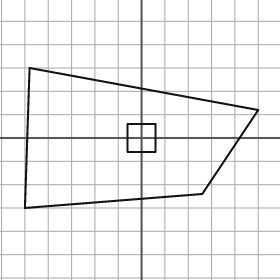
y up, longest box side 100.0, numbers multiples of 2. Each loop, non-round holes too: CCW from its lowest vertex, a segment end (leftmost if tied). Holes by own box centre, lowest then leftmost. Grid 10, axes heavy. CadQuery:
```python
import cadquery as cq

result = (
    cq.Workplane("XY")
    .moveTo(-50.0, -30.0)
    .lineTo(26.0, -24.0)
    .lineTo(50.0, 12.0)
    .lineTo(-48.0, 30.0)
    .close()
    .moveTo(-6.0, -6.0)
    .lineTo(6.0, -6.0)
    .lineTo(6.0, 6.0)
    .lineTo(-6.0, 6.0)
    .close()
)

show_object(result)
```